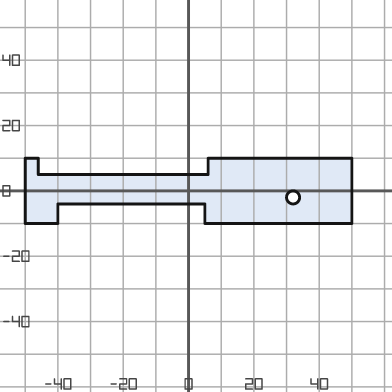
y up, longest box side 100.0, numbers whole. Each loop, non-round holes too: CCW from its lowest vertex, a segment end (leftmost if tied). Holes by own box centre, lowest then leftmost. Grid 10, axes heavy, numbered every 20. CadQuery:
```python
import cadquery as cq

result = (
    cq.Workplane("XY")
    .moveTo(-50.0, -10.0)
    .lineTo(-40.0, -10.0)
    .lineTo(-40.0, -4.0)
    .lineTo(5.0, -4.0)
    .lineTo(5.0, -10.0)
    .lineTo(50.0, -10.0)
    .lineTo(50.0, 10.0)
    .lineTo(6.0, 10.0)
    .lineTo(6.0, 5.0)
    .lineTo(-46.0, 5.0)
    .lineTo(-46.0, 10.0)
    .lineTo(-50.0, 10.0)
    .close()
    .moveTo(32.0, -2.0)
    .circle(2.0)
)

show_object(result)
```